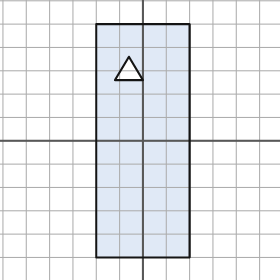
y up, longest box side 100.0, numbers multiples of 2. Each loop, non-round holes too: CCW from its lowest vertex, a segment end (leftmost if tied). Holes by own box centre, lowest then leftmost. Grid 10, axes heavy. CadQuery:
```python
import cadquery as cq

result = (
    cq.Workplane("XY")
    .moveTo(-20.0, -50.0)
    .lineTo(20.0, -50.0)
    .lineTo(20.0, 50.0)
    .lineTo(-20.0, 50.0)
    .close()
    .moveTo(-12.0, 26.0)
    .lineTo(0.0, 26.0)
    .lineTo(-6.0, 36.0)
    .close()
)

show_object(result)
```